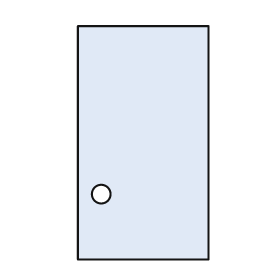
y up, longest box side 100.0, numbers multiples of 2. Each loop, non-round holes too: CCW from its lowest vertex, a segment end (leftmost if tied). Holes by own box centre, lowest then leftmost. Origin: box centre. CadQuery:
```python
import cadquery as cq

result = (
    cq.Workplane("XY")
    .moveTo(-28.0, -50.0)
    .lineTo(28.0, -50.0)
    .lineTo(28.0, 50.0)
    .lineTo(-28.0, 50.0)
    .close()
    .moveTo(-18.0, -22.0)
    .circle(4.0)
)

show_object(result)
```